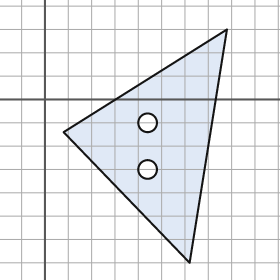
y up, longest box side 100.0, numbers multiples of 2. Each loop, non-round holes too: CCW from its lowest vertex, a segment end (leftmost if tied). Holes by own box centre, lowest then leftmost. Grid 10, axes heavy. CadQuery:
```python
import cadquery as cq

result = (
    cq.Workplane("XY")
    .moveTo(62.0, -70.0)
    .lineTo(78.0, 30.0)
    .lineTo(8.0, -14.0)
    .close()
    .moveTo(44.0, -30.0)
    .circle(4.0)
    .moveTo(44.0, -10.0)
    .circle(4.0)
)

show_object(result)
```